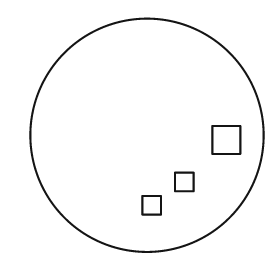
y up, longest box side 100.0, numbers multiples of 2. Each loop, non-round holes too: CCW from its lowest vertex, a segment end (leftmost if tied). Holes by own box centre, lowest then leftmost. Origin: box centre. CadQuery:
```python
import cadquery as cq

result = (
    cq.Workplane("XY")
    .moveTo(0.0, 0.0)
    .circle(50.0)
    .moveTo(-2.0, -34.0)
    .lineTo(6.0, -34.0)
    .lineTo(6.0, -26.0)
    .lineTo(-2.0, -26.0)
    .close()
    .moveTo(12.0, -24.0)
    .lineTo(20.0, -24.0)
    .lineTo(20.0, -16.0)
    .lineTo(12.0, -16.0)
    .close()
    .moveTo(28.0, -8.0)
    .lineTo(40.0, -8.0)
    .lineTo(40.0, 4.0)
    .lineTo(28.0, 4.0)
    .close()
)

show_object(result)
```